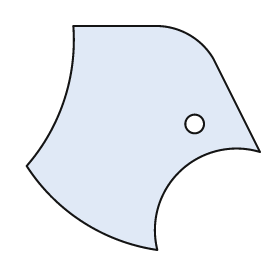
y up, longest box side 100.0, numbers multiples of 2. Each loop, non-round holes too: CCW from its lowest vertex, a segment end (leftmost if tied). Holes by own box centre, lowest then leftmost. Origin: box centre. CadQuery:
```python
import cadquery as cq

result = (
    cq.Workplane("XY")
    .moveTo(6.0, -48.0)
    .threePointArc((16.0, -14.0), (50.0, -6.0))
    .lineTo(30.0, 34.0)
    .threePointArc((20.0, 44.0), (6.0, 48.0))
    .lineTo(-30.0, 48.0)
    .threePointArc((-34.0, 16.0), (-50.0, -12.0))
    .threePointArc((-26.0, -36.0), (6.0, -48.0))
    .close()
    .moveTo(22.0, 6.0)
    .circle(4.0)
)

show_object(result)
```